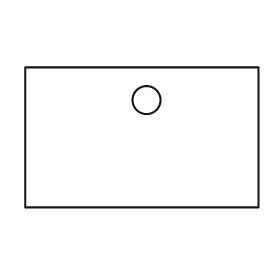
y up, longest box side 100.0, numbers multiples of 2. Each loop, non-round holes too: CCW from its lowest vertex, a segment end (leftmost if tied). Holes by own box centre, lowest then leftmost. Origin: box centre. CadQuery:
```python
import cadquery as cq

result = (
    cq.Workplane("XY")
    .moveTo(-50.0, -30.0)
    .lineTo(50.0, -30.0)
    .lineTo(50.0, 30.0)
    .lineTo(-50.0, 30.0)
    .close()
    .moveTo(2.0, 16.0)
    .circle(6.0)
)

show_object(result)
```